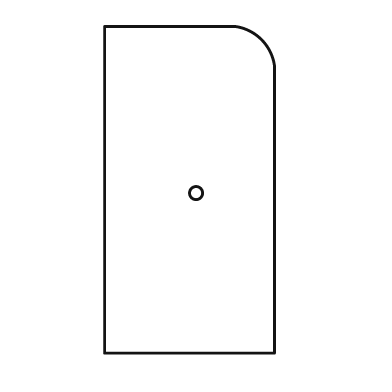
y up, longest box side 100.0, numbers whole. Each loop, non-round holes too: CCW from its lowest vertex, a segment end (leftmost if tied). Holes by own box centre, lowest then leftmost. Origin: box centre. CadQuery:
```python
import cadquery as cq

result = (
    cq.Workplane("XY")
    .moveTo(-26.0, -50.0)
    .lineTo(26.0, -50.0)
    .lineTo(26.0, 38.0)
    .threePointArc((22.0, 46.0), (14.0, 50.0))
    .lineTo(-26.0, 50.0)
    .close()
    .moveTo(2.0, -1.0)
    .circle(2.0)
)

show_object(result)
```